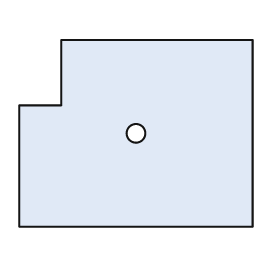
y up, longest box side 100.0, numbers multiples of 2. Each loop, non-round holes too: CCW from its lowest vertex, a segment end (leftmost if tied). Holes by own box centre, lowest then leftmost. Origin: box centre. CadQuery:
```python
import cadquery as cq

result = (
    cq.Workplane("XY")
    .moveTo(-50.0, -40.0)
    .lineTo(50.0, -40.0)
    .lineTo(50.0, 40.0)
    .lineTo(-32.0, 40.0)
    .lineTo(-32.0, 12.0)
    .lineTo(-50.0, 12.0)
    .close()
    .moveTo(0.0, 0.0)
    .circle(4.0)
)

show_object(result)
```